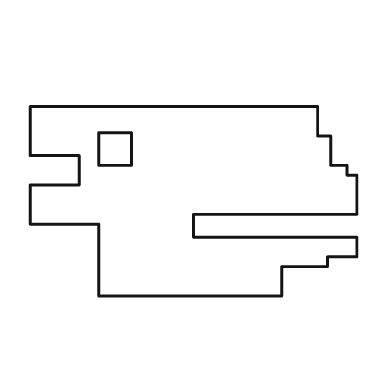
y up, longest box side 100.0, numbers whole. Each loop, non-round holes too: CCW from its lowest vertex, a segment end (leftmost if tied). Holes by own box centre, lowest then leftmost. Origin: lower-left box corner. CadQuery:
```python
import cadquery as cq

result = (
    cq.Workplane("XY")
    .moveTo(21.0, 0.0)
    .lineTo(77.0, 0.0)
    .lineTo(77.0, 9.0)
    .lineTo(91.0, 9.0)
    .lineTo(91.0, 12.0)
    .lineTo(100.0, 12.0)
    .lineTo(100.0, 18.0)
    .lineTo(50.0, 18.0)
    .lineTo(50.0, 25.0)
    .lineTo(100.0, 25.0)
    .lineTo(100.0, 37.0)
    .lineTo(97.0, 37.0)
    .lineTo(97.0, 40.0)
    .lineTo(92.0, 40.0)
    .lineTo(92.0, 49.0)
    .lineTo(88.0, 49.0)
    .lineTo(88.0, 58.0)
    .lineTo(0.0, 58.0)
    .lineTo(0.0, 43.0)
    .lineTo(15.0, 43.0)
    .lineTo(15.0, 34.0)
    .lineTo(0.0, 34.0)
    .lineTo(0.0, 22.0)
    .lineTo(21.0, 22.0)
    .close()
    .moveTo(21.0, 40.0)
    .lineTo(31.0, 40.0)
    .lineTo(31.0, 50.0)
    .lineTo(21.0, 50.0)
    .close()
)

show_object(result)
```